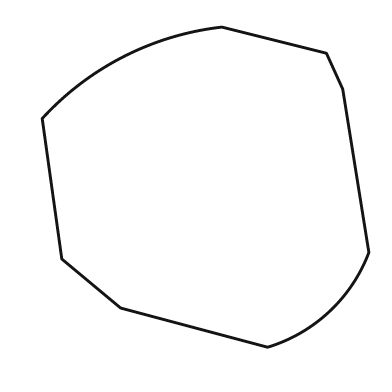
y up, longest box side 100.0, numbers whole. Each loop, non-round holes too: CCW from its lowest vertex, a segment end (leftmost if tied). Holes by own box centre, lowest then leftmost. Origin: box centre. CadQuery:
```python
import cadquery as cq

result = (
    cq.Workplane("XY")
    .moveTo(19.0, -49.0)
    .threePointArc((38.0, -38.0), (50.0, -20.0))
    .lineTo(42.0, 30.0)
    .lineTo(37.0, 41.0)
    .lineTo(5.0, 49.0)
    .threePointArc((-25.0, 40.0), (-50.0, 21.0))
    .lineTo(-44.0, -22.0)
    .lineTo(-26.0, -37.0)
    .close()
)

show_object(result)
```